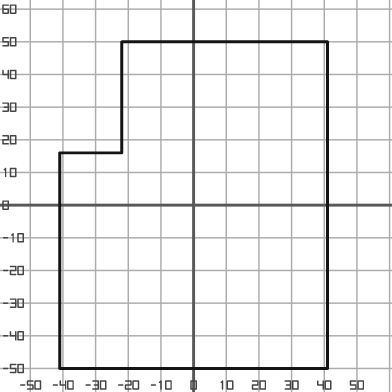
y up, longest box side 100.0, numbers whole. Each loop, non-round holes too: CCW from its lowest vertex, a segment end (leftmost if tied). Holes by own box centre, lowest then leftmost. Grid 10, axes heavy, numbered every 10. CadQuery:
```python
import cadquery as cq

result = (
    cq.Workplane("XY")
    .moveTo(-41.0, -50.0)
    .lineTo(41.0, -50.0)
    .lineTo(41.0, 50.0)
    .lineTo(-22.0, 50.0)
    .lineTo(-22.0, 16.0)
    .lineTo(-41.0, 16.0)
    .close()
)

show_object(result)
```